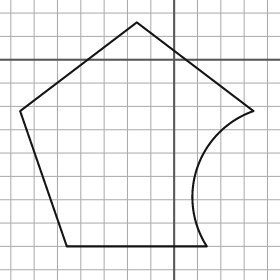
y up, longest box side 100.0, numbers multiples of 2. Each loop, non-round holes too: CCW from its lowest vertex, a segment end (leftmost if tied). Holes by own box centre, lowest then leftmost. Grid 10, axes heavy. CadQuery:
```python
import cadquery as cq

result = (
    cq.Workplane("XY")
    .moveTo(-46.0, -80.0)
    .lineTo(14.0, -80.0)
    .threePointArc((10.0, -46.0), (34.0, -22.0))
    .lineTo(-16.0, 16.0)
    .lineTo(-66.0, -22.0)
    .close()
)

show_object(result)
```